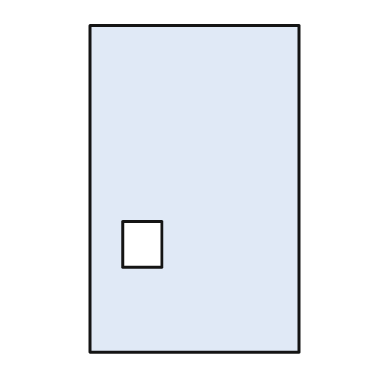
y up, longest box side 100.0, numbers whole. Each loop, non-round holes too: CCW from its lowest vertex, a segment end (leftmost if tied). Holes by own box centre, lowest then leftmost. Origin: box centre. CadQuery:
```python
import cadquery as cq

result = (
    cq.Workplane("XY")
    .moveTo(-32.0, -50.0)
    .lineTo(32.0, -50.0)
    .lineTo(32.0, 50.0)
    .lineTo(-32.0, 50.0)
    .close()
    .moveTo(-22.0, -24.0)
    .lineTo(-10.0, -24.0)
    .lineTo(-10.0, -10.0)
    .lineTo(-22.0, -10.0)
    .close()
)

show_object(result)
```